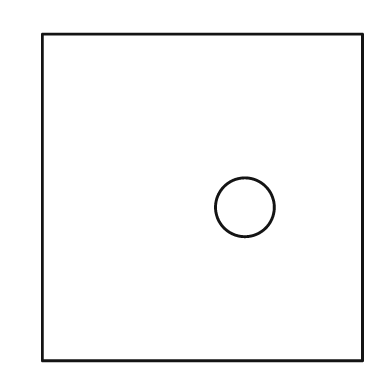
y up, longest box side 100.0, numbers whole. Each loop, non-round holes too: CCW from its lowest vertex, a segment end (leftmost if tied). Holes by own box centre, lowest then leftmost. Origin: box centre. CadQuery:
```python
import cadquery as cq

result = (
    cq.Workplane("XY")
    .moveTo(-49.0, -50.0)
    .lineTo(49.0, -50.0)
    .lineTo(49.0, 50.0)
    .lineTo(-49.0, 50.0)
    .close()
    .moveTo(13.0, -3.0)
    .circle(9.0)
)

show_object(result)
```